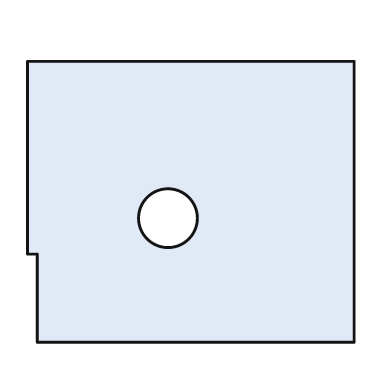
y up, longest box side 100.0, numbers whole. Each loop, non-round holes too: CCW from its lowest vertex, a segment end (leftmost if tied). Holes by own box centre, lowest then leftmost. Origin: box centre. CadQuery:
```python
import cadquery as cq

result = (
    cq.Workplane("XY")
    .moveTo(-47.0, -43.0)
    .lineTo(50.0, -43.0)
    .lineTo(50.0, 43.0)
    .lineTo(-50.0, 43.0)
    .lineTo(-50.0, -16.0)
    .lineTo(-47.0, -16.0)
    .close()
    .moveTo(-7.0, -5.0)
    .circle(9.0)
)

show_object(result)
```